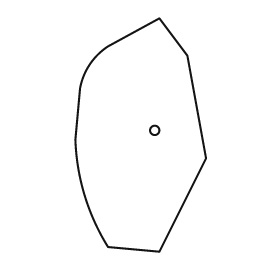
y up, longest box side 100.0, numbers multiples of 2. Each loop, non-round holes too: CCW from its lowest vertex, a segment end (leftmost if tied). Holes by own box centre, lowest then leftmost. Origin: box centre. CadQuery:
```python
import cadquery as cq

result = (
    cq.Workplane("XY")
    .moveTo(8.0, -50.0)
    .lineTo(28.0, -10.0)
    .lineTo(20.0, 34.0)
    .lineTo(8.0, 50.0)
    .lineTo(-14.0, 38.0)
    .threePointArc((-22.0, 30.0), (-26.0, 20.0))
    .lineTo(-28.0, -2.0)
    .threePointArc((-24.0, -26.0), (-14.0, -48.0))
    .close()
    .moveTo(6.0, 2.0)
    .circle(2.0)
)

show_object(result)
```